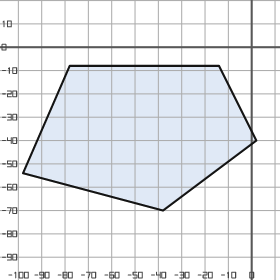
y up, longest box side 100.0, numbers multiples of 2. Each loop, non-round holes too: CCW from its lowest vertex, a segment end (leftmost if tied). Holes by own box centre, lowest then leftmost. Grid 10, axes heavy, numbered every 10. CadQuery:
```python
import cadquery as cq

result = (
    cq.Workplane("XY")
    .moveTo(-38.0, -70.0)
    .lineTo(2.0, -40.0)
    .lineTo(-14.0, -8.0)
    .lineTo(-78.0, -8.0)
    .lineTo(-98.0, -54.0)
    .close()
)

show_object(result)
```